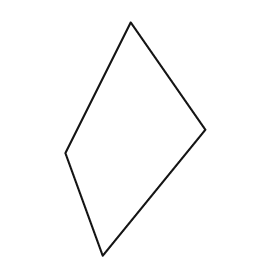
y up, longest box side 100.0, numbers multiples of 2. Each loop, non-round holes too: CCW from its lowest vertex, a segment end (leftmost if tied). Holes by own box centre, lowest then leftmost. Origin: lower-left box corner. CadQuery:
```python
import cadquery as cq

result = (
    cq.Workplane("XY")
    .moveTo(16.0, 0.0)
    .lineTo(60.0, 54.0)
    .lineTo(28.0, 100.0)
    .lineTo(0.0, 44.0)
    .close()
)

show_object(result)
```